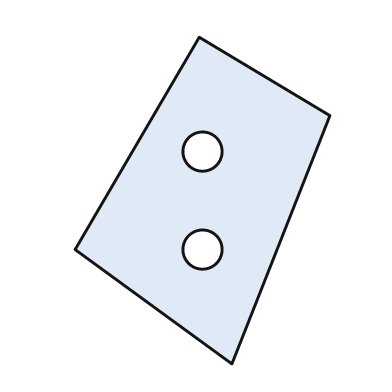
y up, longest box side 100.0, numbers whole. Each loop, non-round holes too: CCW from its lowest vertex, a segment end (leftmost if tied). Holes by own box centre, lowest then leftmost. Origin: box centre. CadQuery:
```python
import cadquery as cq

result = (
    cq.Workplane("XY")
    .moveTo(9.0, -50.0)
    .lineTo(39.0, 26.0)
    .lineTo(-1.0, 50.0)
    .lineTo(-39.0, -15.0)
    .close()
    .moveTo(0.0, -15.0)
    .circle(6.0)
    .moveTo(0.0, 15.0)
    .circle(6.0)
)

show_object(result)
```